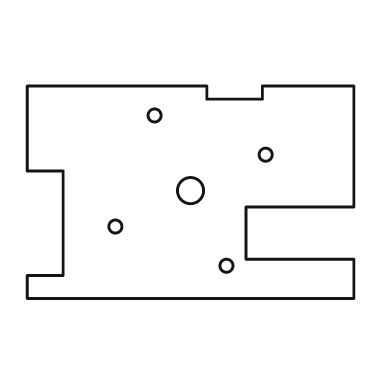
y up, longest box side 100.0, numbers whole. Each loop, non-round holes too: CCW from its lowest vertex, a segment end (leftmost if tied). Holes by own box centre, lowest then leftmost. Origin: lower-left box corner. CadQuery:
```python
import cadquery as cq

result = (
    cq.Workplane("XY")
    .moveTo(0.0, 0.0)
    .lineTo(100.0, 0.0)
    .lineTo(100.0, 12.0)
    .lineTo(67.0, 12.0)
    .lineTo(67.0, 28.0)
    .lineTo(100.0, 28.0)
    .lineTo(100.0, 65.0)
    .lineTo(72.0, 65.0)
    .lineTo(72.0, 61.0)
    .lineTo(55.0, 61.0)
    .lineTo(55.0, 65.0)
    .lineTo(0.0, 65.0)
    .lineTo(0.0, 39.0)
    .lineTo(11.0, 39.0)
    .lineTo(11.0, 7.0)
    .lineTo(0.0, 7.0)
    .close()
    .moveTo(61.0, 10.0)
    .circle(2.0)
    .moveTo(27.0, 22.0)
    .circle(2.0)
    .moveTo(50.0, 33.0)
    .circle(4.0)
    .moveTo(73.0, 44.0)
    .circle(2.0)
    .moveTo(39.0, 56.0)
    .circle(2.0)
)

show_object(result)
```